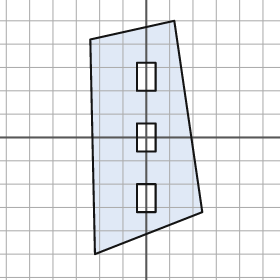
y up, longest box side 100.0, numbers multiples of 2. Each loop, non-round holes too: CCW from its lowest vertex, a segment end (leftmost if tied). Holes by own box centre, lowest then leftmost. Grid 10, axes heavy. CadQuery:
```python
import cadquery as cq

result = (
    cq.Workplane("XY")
    .moveTo(-22.0, -50.0)
    .lineTo(24.0, -32.0)
    .lineTo(12.0, 50.0)
    .lineTo(-24.0, 42.0)
    .close()
    .moveTo(-4.0, -32.0)
    .lineTo(4.0, -32.0)
    .lineTo(4.0, -20.0)
    .lineTo(-4.0, -20.0)
    .close()
    .moveTo(-4.0, -6.0)
    .lineTo(4.0, -6.0)
    .lineTo(4.0, 6.0)
    .lineTo(-4.0, 6.0)
    .close()
    .moveTo(-4.0, 20.0)
    .lineTo(4.0, 20.0)
    .lineTo(4.0, 32.0)
    .lineTo(-4.0, 32.0)
    .close()
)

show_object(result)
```